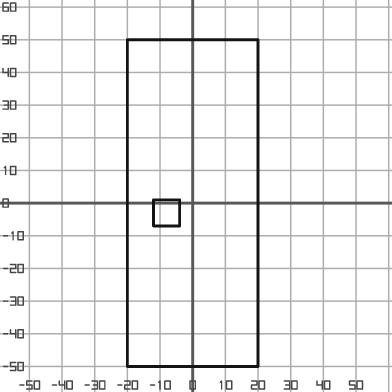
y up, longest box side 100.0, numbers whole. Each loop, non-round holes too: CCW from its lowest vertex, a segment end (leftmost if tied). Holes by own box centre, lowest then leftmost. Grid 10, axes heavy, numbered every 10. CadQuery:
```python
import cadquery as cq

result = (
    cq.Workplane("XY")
    .moveTo(-20.0, -50.0)
    .lineTo(20.0, -50.0)
    .lineTo(20.0, 50.0)
    .lineTo(-20.0, 50.0)
    .close()
    .moveTo(-12.0, -7.0)
    .lineTo(-4.0, -7.0)
    .lineTo(-4.0, 1.0)
    .lineTo(-12.0, 1.0)
    .close()
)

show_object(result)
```